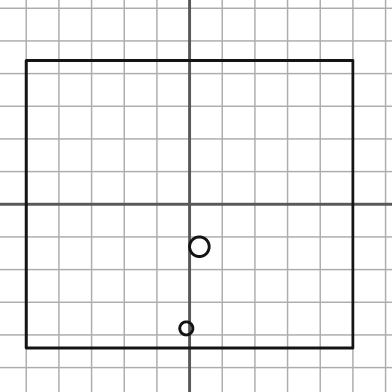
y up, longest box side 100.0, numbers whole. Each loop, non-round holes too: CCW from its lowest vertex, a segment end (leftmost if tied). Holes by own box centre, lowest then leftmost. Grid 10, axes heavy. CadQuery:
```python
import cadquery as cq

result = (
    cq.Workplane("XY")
    .moveTo(-50.0, -44.0)
    .lineTo(50.0, -44.0)
    .lineTo(50.0, 44.0)
    .lineTo(-50.0, 44.0)
    .close()
    .moveTo(-1.0, -38.0)
    .circle(2.0)
    .moveTo(3.0, -13.0)
    .circle(3.0)
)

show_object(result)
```